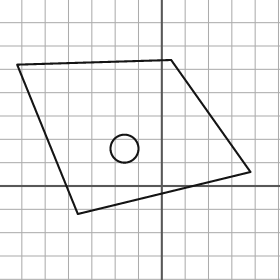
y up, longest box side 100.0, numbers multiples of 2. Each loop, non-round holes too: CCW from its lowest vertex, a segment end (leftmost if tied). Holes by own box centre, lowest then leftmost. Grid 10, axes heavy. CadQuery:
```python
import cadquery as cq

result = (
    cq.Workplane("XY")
    .moveTo(-36.0, -12.0)
    .lineTo(38.0, 6.0)
    .lineTo(4.0, 54.0)
    .lineTo(-62.0, 52.0)
    .close()
    .moveTo(-16.0, 16.0)
    .circle(6.0)
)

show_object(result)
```